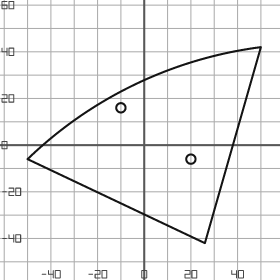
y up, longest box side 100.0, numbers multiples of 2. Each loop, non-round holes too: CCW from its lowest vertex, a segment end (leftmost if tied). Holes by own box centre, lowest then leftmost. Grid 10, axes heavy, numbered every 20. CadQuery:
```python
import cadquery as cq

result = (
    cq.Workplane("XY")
    .moveTo(26.0, -42.0)
    .lineTo(50.0, 42.0)
    .threePointArc((-4.0, 26.0), (-50.0, -6.0))
    .close()
    .moveTo(20.0, -6.0)
    .circle(2.0)
    .moveTo(-10.0, 16.0)
    .circle(2.0)
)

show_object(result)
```